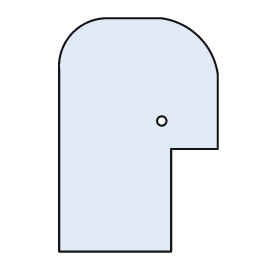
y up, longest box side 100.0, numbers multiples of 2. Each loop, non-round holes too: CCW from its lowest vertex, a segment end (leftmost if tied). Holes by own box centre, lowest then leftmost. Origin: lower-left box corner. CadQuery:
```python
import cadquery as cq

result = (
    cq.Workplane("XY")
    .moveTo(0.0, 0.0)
    .lineTo(48.0, 0.0)
    .lineTo(48.0, 44.0)
    .lineTo(68.0, 44.0)
    .lineTo(68.0, 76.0)
    .threePointArc((60.0, 92.0), (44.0, 100.0))
    .lineTo(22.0, 100.0)
    .threePointArc((6.0, 94.0), (0.0, 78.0))
    .close()
    .moveTo(44.0, 56.0)
    .circle(2.0)
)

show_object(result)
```